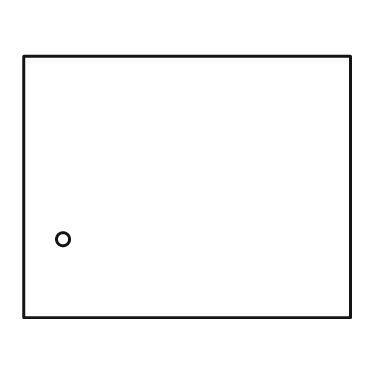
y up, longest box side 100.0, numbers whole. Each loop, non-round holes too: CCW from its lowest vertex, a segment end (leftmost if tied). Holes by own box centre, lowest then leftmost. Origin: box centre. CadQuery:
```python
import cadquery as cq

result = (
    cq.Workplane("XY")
    .moveTo(-50.0, -40.0)
    .lineTo(50.0, -40.0)
    .lineTo(50.0, 40.0)
    .lineTo(-50.0, 40.0)
    .close()
    .moveTo(-38.0, -16.0)
    .circle(2.0)
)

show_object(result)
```